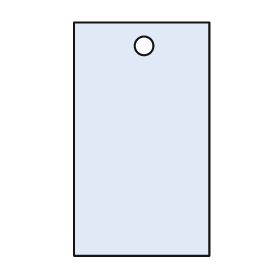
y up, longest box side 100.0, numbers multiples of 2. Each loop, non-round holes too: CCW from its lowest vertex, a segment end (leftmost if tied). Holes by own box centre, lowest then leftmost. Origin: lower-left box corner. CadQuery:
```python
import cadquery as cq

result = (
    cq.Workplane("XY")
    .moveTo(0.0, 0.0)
    .lineTo(58.0, 0.0)
    .lineTo(58.0, 100.0)
    .lineTo(0.0, 100.0)
    .close()
    .moveTo(30.0, 90.0)
    .circle(4.0)
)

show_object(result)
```